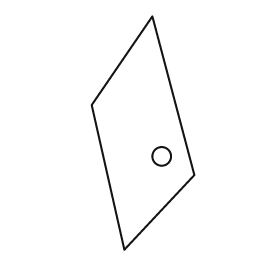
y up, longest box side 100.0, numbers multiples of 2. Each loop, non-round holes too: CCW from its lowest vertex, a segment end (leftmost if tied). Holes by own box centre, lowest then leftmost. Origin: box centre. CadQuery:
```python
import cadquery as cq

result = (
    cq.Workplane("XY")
    .moveTo(-8.0, -50.0)
    .lineTo(22.0, -18.0)
    .lineTo(4.0, 50.0)
    .lineTo(-22.0, 12.0)
    .close()
    .moveTo(8.0, -10.0)
    .circle(4.0)
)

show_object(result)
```